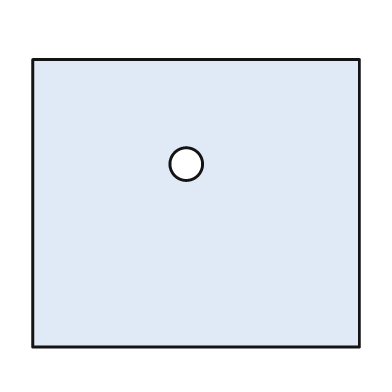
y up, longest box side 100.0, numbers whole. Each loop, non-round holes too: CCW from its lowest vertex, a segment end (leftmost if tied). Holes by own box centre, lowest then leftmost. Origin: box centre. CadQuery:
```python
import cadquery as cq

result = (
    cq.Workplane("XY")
    .moveTo(-50.0, -44.0)
    .lineTo(50.0, -44.0)
    .lineTo(50.0, 44.0)
    .lineTo(-50.0, 44.0)
    .close()
    .moveTo(-3.0, 12.0)
    .circle(5.0)
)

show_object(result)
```